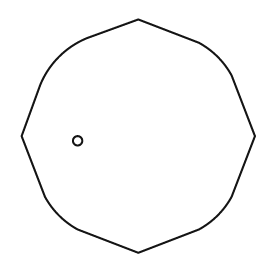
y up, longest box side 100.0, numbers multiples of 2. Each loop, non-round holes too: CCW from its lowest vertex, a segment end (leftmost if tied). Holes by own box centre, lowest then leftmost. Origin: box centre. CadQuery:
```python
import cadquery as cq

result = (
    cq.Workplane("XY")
    .moveTo(0.0, -50.0)
    .lineTo(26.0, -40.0)
    .threePointArc((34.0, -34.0), (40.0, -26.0))
    .lineTo(50.0, 0.0)
    .lineTo(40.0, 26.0)
    .threePointArc((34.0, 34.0), (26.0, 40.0))
    .lineTo(0.0, 50.0)
    .lineTo(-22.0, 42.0)
    .threePointArc((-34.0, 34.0), (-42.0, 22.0))
    .lineTo(-50.0, 0.0)
    .lineTo(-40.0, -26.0)
    .threePointArc((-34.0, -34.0), (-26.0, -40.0))
    .close()
    .moveTo(-26.0, -2.0)
    .circle(2.0)
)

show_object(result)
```